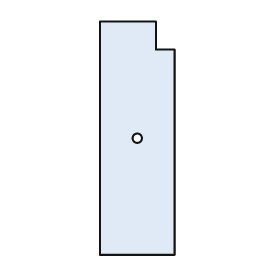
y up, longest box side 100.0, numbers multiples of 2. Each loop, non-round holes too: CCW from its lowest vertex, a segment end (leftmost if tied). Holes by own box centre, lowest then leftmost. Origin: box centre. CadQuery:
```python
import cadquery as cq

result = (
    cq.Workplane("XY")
    .moveTo(-16.0, -50.0)
    .lineTo(16.0, -50.0)
    .lineTo(16.0, 38.0)
    .lineTo(8.0, 38.0)
    .lineTo(8.0, 50.0)
    .lineTo(-16.0, 50.0)
    .close()
    .moveTo(0.0, 0.0)
    .circle(2.0)
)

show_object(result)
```